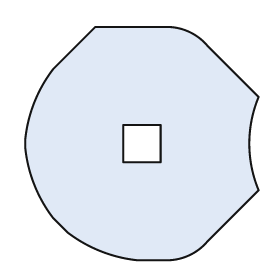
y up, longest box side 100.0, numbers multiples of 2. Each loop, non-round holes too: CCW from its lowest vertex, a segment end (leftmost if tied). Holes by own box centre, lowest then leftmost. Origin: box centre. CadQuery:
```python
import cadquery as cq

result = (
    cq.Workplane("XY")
    .moveTo(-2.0, -50.0)
    .lineTo(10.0, -50.0)
    .threePointArc((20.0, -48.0), (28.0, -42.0))
    .lineTo(50.0, -20.0)
    .threePointArc((46.0, 0.0), (50.0, 20.0))
    .lineTo(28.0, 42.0)
    .threePointArc((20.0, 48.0), (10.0, 50.0))
    .lineTo(-20.0, 50.0)
    .lineTo(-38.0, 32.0)
    .threePointArc((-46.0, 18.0), (-50.0, 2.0))
    .lineTo(-50.0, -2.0)
    .threePointArc((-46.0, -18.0), (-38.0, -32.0))
    .lineTo(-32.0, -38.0)
    .threePointArc((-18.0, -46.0), (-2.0, -50.0))
    .close()
    .moveTo(-8.0, -8.0)
    .lineTo(8.0, -8.0)
    .lineTo(8.0, 8.0)
    .lineTo(-8.0, 8.0)
    .close()
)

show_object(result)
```